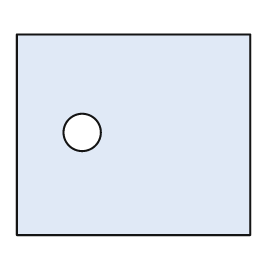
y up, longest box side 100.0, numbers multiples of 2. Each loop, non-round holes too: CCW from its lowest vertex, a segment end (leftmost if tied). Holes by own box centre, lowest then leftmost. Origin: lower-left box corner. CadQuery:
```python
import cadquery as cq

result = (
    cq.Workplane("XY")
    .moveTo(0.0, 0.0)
    .lineTo(100.0, 0.0)
    .lineTo(100.0, 86.0)
    .lineTo(0.0, 86.0)
    .close()
    .moveTo(28.0, 44.0)
    .circle(8.0)
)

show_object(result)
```